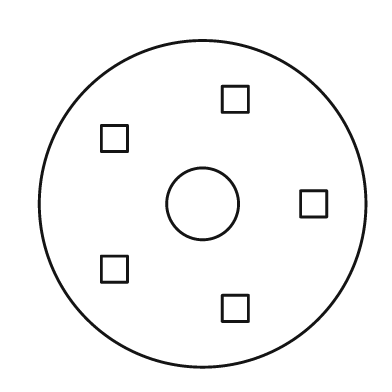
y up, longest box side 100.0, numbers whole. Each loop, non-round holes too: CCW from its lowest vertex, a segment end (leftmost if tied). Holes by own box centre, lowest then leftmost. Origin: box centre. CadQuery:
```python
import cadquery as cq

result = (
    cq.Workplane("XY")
    .moveTo(0.0, 0.0)
    .circle(50.0)
    .moveTo(6.0, -36.0)
    .lineTo(14.0, -36.0)
    .lineTo(14.0, -28.0)
    .lineTo(6.0, -28.0)
    .close()
    .moveTo(-31.0, -24.0)
    .lineTo(-23.0, -24.0)
    .lineTo(-23.0, -16.0)
    .lineTo(-31.0, -16.0)
    .close()
    .moveTo(0.0, 0.0)
    .circle(11.0)
    .moveTo(30.0, -4.0)
    .lineTo(38.0, -4.0)
    .lineTo(38.0, 4.0)
    .lineTo(30.0, 4.0)
    .close()
    .moveTo(-31.0, 16.0)
    .lineTo(-23.0, 16.0)
    .lineTo(-23.0, 24.0)
    .lineTo(-31.0, 24.0)
    .close()
    .moveTo(6.0, 28.0)
    .lineTo(14.0, 28.0)
    .lineTo(14.0, 36.0)
    .lineTo(6.0, 36.0)
    .close()
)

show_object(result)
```